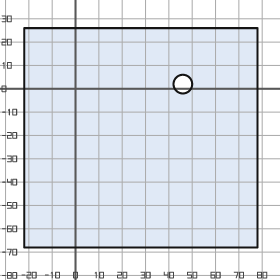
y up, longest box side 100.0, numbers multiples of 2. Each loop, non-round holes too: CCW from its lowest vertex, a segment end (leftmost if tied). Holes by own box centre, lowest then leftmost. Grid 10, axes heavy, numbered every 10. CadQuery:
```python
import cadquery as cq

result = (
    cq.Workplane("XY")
    .moveTo(-22.0, -68.0)
    .lineTo(78.0, -68.0)
    .lineTo(78.0, 26.0)
    .lineTo(-22.0, 26.0)
    .close()
    .moveTo(46.0, 2.0)
    .circle(4.0)
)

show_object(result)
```